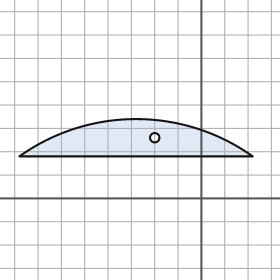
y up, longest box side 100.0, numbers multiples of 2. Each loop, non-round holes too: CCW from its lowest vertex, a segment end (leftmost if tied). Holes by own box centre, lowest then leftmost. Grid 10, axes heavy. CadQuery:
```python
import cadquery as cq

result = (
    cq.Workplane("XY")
    .moveTo(-78.0, 18.0)
    .lineTo(22.0, 18.0)
    .threePointArc((-28.0, 34.0), (-78.0, 18.0))
    .close()
    .moveTo(-20.0, 26.0)
    .circle(2.0)
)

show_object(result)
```